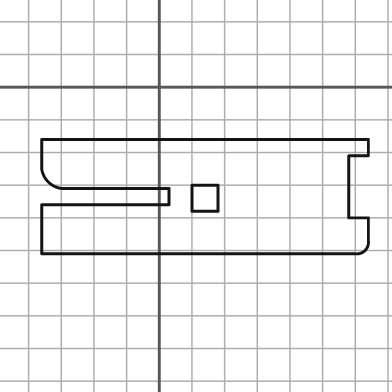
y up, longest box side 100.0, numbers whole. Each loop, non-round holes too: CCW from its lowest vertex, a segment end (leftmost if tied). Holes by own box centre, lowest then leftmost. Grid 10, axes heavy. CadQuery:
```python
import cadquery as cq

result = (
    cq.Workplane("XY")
    .moveTo(-36.0, -51.0)
    .lineTo(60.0, -51.0)
    .threePointArc((63.0, -50.0), (64.0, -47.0))
    .lineTo(64.0, -40.0)
    .lineTo(58.0, -40.0)
    .lineTo(58.0, -21.0)
    .lineTo(64.0, -21.0)
    .lineTo(64.0, -16.0)
    .lineTo(-36.0, -16.0)
    .lineTo(-36.0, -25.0)
    .threePointArc((-34.0, -29.0), (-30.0, -31.0))
    .lineTo(3.0, -31.0)
    .lineTo(3.0, -36.0)
    .lineTo(-36.0, -36.0)
    .close()
    .moveTo(10.0, -38.0)
    .lineTo(18.0, -38.0)
    .lineTo(18.0, -30.0)
    .lineTo(10.0, -30.0)
    .close()
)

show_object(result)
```